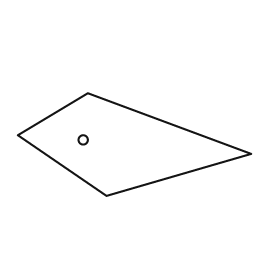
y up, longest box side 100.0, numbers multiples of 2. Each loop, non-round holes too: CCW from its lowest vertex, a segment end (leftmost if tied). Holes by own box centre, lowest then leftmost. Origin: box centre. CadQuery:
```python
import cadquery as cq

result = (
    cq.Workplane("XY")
    .moveTo(-12.0, -22.0)
    .lineTo(50.0, -4.0)
    .lineTo(-20.0, 22.0)
    .lineTo(-50.0, 4.0)
    .close()
    .moveTo(-22.0, 2.0)
    .circle(2.0)
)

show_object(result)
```